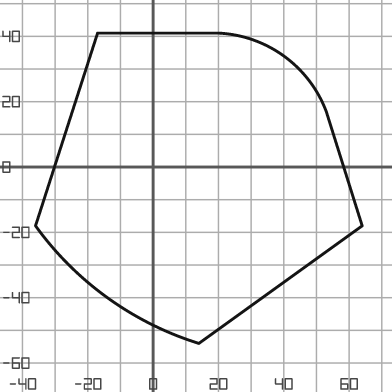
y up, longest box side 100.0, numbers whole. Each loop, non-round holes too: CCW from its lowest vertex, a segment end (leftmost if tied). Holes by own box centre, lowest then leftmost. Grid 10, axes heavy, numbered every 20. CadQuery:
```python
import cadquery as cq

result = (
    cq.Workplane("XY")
    .moveTo(14.0, -54.0)
    .lineTo(64.0, -18.0)
    .lineTo(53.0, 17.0)
    .threePointArc((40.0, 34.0), (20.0, 41.0))
    .lineTo(-17.0, 41.0)
    .lineTo(-36.0, -18.0)
    .threePointArc((-14.0, -40.0), (14.0, -54.0))
    .close()
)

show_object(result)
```